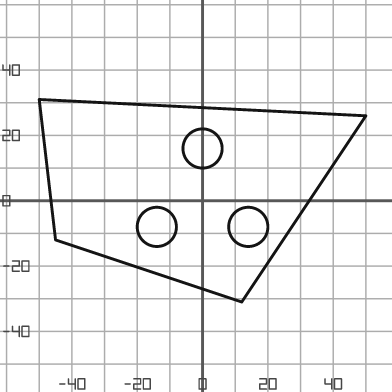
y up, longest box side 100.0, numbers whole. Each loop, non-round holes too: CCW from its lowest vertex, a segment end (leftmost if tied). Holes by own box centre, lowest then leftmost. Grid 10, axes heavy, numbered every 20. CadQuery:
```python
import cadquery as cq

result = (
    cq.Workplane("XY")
    .moveTo(12.0, -31.0)
    .lineTo(50.0, 26.0)
    .lineTo(-50.0, 31.0)
    .lineTo(-45.0, -12.0)
    .close()
    .moveTo(-14.0, -8.0)
    .circle(6.0)
    .moveTo(14.0, -8.0)
    .circle(6.0)
    .moveTo(0.0, 16.0)
    .circle(6.0)
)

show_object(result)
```